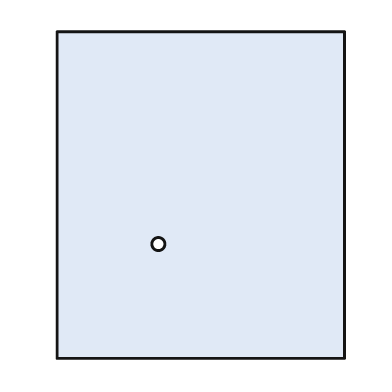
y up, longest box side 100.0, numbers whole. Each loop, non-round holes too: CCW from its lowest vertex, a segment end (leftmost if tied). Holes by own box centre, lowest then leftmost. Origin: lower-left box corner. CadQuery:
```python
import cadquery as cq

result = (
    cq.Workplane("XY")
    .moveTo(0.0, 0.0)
    .lineTo(88.0, 0.0)
    .lineTo(88.0, 100.0)
    .lineTo(0.0, 100.0)
    .close()
    .moveTo(31.0, 35.0)
    .circle(2.0)
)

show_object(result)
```